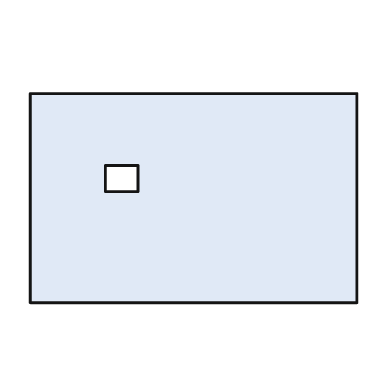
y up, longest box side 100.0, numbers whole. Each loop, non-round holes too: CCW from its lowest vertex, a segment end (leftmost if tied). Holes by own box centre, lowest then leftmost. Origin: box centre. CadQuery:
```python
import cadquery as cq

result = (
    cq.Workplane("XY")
    .moveTo(-50.0, -32.0)
    .lineTo(50.0, -32.0)
    .lineTo(50.0, 32.0)
    .lineTo(-50.0, 32.0)
    .close()
    .moveTo(-27.0, 2.0)
    .lineTo(-17.0, 2.0)
    .lineTo(-17.0, 10.0)
    .lineTo(-27.0, 10.0)
    .close()
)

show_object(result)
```